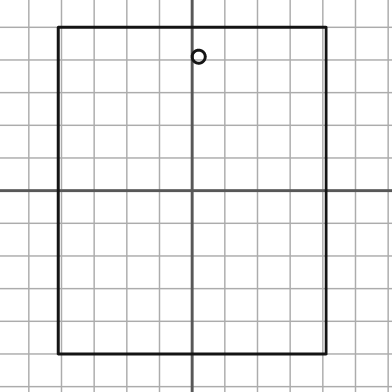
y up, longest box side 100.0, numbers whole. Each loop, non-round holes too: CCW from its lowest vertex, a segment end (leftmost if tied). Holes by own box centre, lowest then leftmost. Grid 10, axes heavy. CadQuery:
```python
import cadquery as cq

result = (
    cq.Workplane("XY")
    .moveTo(-41.0, -50.0)
    .lineTo(41.0, -50.0)
    .lineTo(41.0, 50.0)
    .lineTo(-41.0, 50.0)
    .close()
    .moveTo(2.0, 41.0)
    .circle(2.0)
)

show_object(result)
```